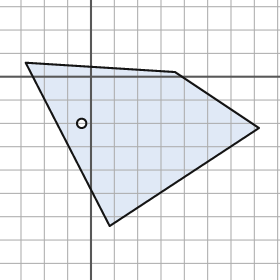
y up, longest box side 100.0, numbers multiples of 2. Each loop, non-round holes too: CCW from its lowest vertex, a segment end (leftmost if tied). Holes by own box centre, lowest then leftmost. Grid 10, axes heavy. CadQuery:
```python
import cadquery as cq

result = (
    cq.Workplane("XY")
    .moveTo(8.0, -64.0)
    .lineTo(72.0, -22.0)
    .lineTo(36.0, 2.0)
    .lineTo(-28.0, 6.0)
    .close()
    .moveTo(-4.0, -20.0)
    .circle(2.0)
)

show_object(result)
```